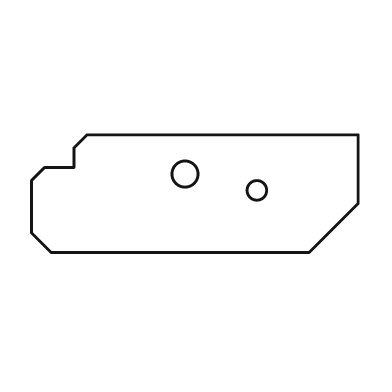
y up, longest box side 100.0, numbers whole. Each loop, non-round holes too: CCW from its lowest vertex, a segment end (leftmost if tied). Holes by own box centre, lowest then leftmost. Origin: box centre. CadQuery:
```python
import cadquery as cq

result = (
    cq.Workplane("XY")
    .moveTo(-44.0, -18.0)
    .lineTo(35.0, -18.0)
    .lineTo(50.0, -3.0)
    .lineTo(50.0, 18.0)
    .lineTo(-33.0, 18.0)
    .lineTo(-37.0, 14.0)
    .lineTo(-37.0, 8.0)
    .lineTo(-46.0, 8.0)
    .lineTo(-50.0, 4.0)
    .lineTo(-50.0, -12.0)
    .close()
    .moveTo(19.0, 1.0)
    .circle(3.0)
    .moveTo(-3.0, 6.0)
    .circle(4.0)
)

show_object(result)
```